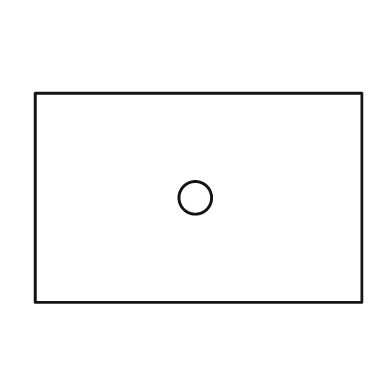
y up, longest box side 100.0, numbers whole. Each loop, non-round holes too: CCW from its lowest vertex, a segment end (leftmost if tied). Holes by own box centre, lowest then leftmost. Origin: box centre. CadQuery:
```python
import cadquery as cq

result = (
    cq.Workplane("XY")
    .moveTo(-50.0, -32.0)
    .lineTo(50.0, -32.0)
    .lineTo(50.0, 32.0)
    .lineTo(-50.0, 32.0)
    .close()
    .moveTo(-1.0, 0.0)
    .circle(5.0)
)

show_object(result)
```